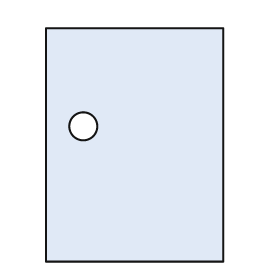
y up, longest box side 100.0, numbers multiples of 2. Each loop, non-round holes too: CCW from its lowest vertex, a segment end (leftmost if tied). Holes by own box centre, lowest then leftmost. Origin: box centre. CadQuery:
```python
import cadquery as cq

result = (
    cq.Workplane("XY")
    .moveTo(-38.0, -50.0)
    .lineTo(38.0, -50.0)
    .lineTo(38.0, 50.0)
    .lineTo(-38.0, 50.0)
    .close()
    .moveTo(-22.0, 8.0)
    .circle(6.0)
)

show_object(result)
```